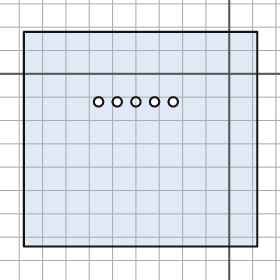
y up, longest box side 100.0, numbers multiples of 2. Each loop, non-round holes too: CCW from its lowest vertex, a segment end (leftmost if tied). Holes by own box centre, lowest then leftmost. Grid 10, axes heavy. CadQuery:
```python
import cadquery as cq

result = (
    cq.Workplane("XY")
    .moveTo(-88.0, -74.0)
    .lineTo(12.0, -74.0)
    .lineTo(12.0, 18.0)
    .lineTo(-88.0, 18.0)
    .close()
    .moveTo(-56.0, -12.0)
    .circle(2.0)
    .moveTo(-48.0, -12.0)
    .circle(2.0)
    .moveTo(-40.0, -12.0)
    .circle(2.0)
    .moveTo(-32.0, -12.0)
    .circle(2.0)
    .moveTo(-24.0, -12.0)
    .circle(2.0)
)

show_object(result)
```